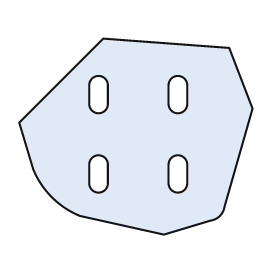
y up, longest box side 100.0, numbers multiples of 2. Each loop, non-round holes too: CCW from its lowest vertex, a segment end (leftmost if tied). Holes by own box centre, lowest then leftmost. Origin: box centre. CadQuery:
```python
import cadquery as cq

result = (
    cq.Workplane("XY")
    .moveTo(12.0, -42.0)
    .lineTo(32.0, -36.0)
    .threePointArc((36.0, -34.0), (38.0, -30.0))
    .lineTo(50.0, 12.0)
    .lineTo(40.0, 38.0)
    .lineTo(-14.0, 42.0)
    .lineTo(-50.0, 6.0)
    .lineTo(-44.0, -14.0)
    .threePointArc((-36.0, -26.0), (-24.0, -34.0))
    .close()
    .moveTo(-20.0, -20.0)
    .threePointArc((-16.0, -24.0), (-12.0, -20.0))
    .lineTo(-12.0, -12.0)
    .threePointArc((-16.0, -8.0), (-20.0, -12.0))
    .close()
    .moveTo(14.0, -20.0)
    .threePointArc((18.0, -24.0), (22.0, -20.0))
    .lineTo(22.0, -12.0)
    .threePointArc((18.0, -8.0), (14.0, -12.0))
    .close()
    .moveTo(-20.0, 14.0)
    .threePointArc((-16.0, 10.0), (-12.0, 14.0))
    .lineTo(-12.0, 22.0)
    .threePointArc((-16.0, 26.0), (-20.0, 22.0))
    .close()
    .moveTo(14.0, 14.0)
    .threePointArc((18.0, 10.0), (22.0, 14.0))
    .lineTo(22.0, 22.0)
    .threePointArc((18.0, 26.0), (14.0, 22.0))
    .close()
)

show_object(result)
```